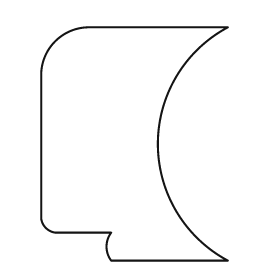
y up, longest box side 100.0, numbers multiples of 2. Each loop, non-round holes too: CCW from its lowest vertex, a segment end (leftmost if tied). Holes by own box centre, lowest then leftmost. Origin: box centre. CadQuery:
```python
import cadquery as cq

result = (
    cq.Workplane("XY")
    .moveTo(-10.0, -50.0)
    .lineTo(40.0, -50.0)
    .threePointArc((10.0, 0.0), (40.0, 50.0))
    .lineTo(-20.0, 50.0)
    .threePointArc((-34.0, 44.0), (-40.0, 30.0))
    .lineTo(-40.0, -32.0)
    .threePointArc((-38.0, -36.0), (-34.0, -38.0))
    .lineTo(-10.0, -38.0)
    .threePointArc((-12.0, -44.0), (-10.0, -50.0))
    .close()
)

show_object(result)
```